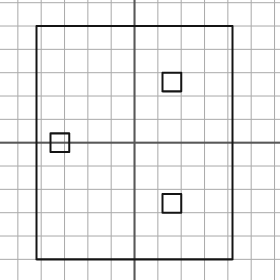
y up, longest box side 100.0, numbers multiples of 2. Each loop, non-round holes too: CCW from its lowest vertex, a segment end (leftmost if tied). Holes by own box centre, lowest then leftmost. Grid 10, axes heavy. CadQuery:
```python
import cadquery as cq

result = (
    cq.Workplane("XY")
    .moveTo(-42.0, -50.0)
    .lineTo(42.0, -50.0)
    .lineTo(42.0, 50.0)
    .lineTo(-42.0, 50.0)
    .close()
    .moveTo(12.0, -30.0)
    .lineTo(20.0, -30.0)
    .lineTo(20.0, -22.0)
    .lineTo(12.0, -22.0)
    .close()
    .moveTo(-36.0, -4.0)
    .lineTo(-28.0, -4.0)
    .lineTo(-28.0, 4.0)
    .lineTo(-36.0, 4.0)
    .close()
    .moveTo(12.0, 22.0)
    .lineTo(20.0, 22.0)
    .lineTo(20.0, 30.0)
    .lineTo(12.0, 30.0)
    .close()
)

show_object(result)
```